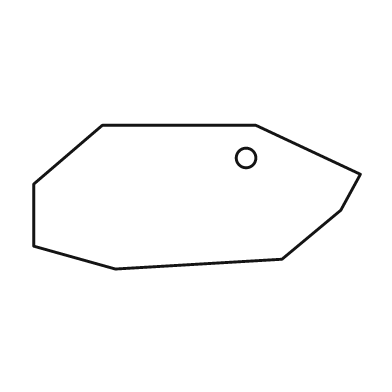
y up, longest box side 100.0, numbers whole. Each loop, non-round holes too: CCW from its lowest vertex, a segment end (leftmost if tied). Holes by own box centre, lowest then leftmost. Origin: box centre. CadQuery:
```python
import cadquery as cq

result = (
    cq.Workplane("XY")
    .moveTo(-25.0, -22.0)
    .lineTo(26.0, -19.0)
    .lineTo(44.0, -4.0)
    .lineTo(50.0, 7.0)
    .lineTo(18.0, 22.0)
    .lineTo(-29.0, 22.0)
    .lineTo(-50.0, 4.0)
    .lineTo(-50.0, -15.0)
    .close()
    .moveTo(15.0, 12.0)
    .circle(3.0)
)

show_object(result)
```